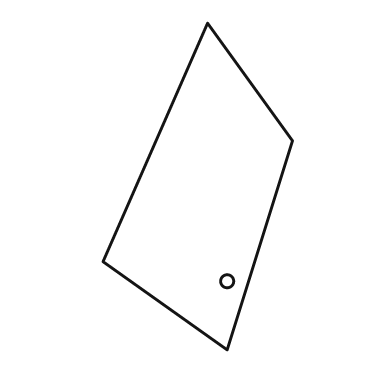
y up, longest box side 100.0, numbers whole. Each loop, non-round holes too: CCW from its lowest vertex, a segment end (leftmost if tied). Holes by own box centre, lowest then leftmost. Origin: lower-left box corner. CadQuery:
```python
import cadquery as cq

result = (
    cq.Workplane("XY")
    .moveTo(38.0, 0.0)
    .lineTo(58.0, 64.0)
    .lineTo(32.0, 100.0)
    .lineTo(0.0, 27.0)
    .close()
    .moveTo(38.0, 21.0)
    .circle(2.0)
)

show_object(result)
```